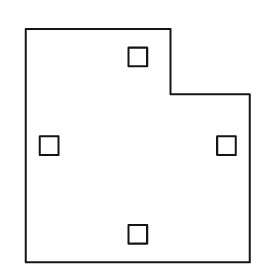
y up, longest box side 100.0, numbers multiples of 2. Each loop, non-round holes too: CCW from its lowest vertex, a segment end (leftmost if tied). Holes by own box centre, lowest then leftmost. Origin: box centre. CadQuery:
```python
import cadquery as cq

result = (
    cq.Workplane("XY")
    .moveTo(-48.0, -50.0)
    .lineTo(48.0, -50.0)
    .lineTo(48.0, 22.0)
    .lineTo(14.0, 22.0)
    .lineTo(14.0, 50.0)
    .lineTo(-48.0, 50.0)
    .close()
    .moveTo(-4.0, -42.0)
    .lineTo(4.0, -42.0)
    .lineTo(4.0, -34.0)
    .lineTo(-4.0, -34.0)
    .close()
    .moveTo(-42.0, -4.0)
    .lineTo(-34.0, -4.0)
    .lineTo(-34.0, 4.0)
    .lineTo(-42.0, 4.0)
    .close()
    .moveTo(34.0, -4.0)
    .lineTo(42.0, -4.0)
    .lineTo(42.0, 4.0)
    .lineTo(34.0, 4.0)
    .close()
    .moveTo(-4.0, 34.0)
    .lineTo(4.0, 34.0)
    .lineTo(4.0, 42.0)
    .lineTo(-4.0, 42.0)
    .close()
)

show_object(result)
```